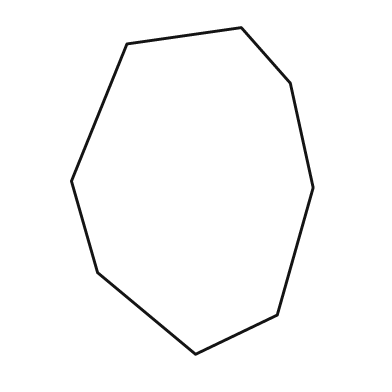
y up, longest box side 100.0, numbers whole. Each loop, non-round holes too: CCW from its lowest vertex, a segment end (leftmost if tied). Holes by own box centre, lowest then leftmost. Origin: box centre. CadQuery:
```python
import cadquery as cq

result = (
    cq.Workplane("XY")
    .moveTo(1.0, -50.0)
    .lineTo(26.0, -38.0)
    .lineTo(37.0, 1.0)
    .lineTo(30.0, 33.0)
    .lineTo(15.0, 50.0)
    .lineTo(-20.0, 45.0)
    .lineTo(-37.0, 3.0)
    .lineTo(-29.0, -25.0)
    .close()
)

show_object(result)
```